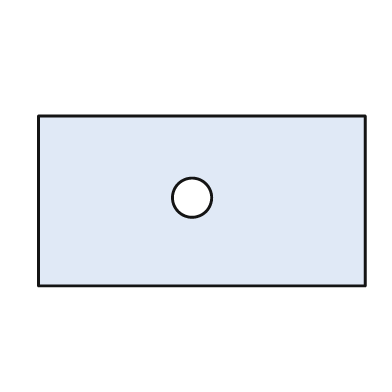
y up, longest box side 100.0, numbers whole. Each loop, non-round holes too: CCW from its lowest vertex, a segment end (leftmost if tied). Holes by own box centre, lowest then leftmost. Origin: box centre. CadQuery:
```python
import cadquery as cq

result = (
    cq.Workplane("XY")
    .moveTo(-50.0, -26.0)
    .lineTo(50.0, -26.0)
    .lineTo(50.0, 26.0)
    .lineTo(-50.0, 26.0)
    .close()
    .moveTo(-3.0, 1.0)
    .circle(6.0)
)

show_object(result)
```